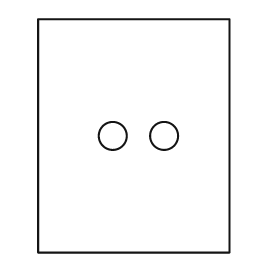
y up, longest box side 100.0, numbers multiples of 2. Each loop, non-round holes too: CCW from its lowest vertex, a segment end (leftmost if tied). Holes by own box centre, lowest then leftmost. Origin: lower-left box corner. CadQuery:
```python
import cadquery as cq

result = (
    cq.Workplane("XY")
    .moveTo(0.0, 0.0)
    .lineTo(82.0, 0.0)
    .lineTo(82.0, 100.0)
    .lineTo(0.0, 100.0)
    .close()
    .moveTo(32.0, 50.0)
    .circle(6.0)
    .moveTo(54.0, 50.0)
    .circle(6.0)
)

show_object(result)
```